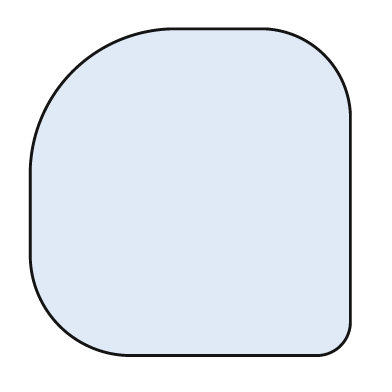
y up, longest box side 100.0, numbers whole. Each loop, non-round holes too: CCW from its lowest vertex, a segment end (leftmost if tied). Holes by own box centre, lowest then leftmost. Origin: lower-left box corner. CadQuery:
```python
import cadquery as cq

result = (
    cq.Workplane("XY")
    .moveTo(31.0, 0.0)
    .lineTo(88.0, 0.0)
    .threePointArc((95.0, 3.0), (98.0, 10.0))
    .lineTo(98.0, 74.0)
    .threePointArc((90.0, 92.0), (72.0, 100.0))
    .lineTo(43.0, 100.0)
    .threePointArc((13.0, 87.0), (0.0, 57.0))
    .lineTo(0.0, 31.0)
    .threePointArc((9.0, 9.0), (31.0, 0.0))
    .close()
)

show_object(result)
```